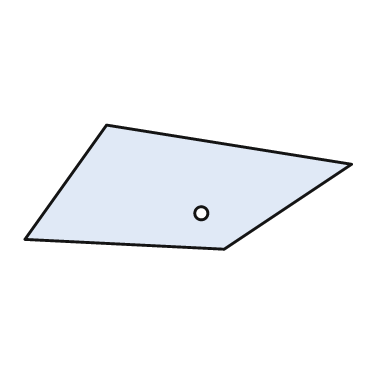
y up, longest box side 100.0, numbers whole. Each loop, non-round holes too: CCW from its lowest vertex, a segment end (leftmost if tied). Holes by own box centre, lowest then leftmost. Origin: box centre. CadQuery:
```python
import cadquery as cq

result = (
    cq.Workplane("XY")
    .moveTo(11.0, -19.0)
    .lineTo(50.0, 7.0)
    .lineTo(-25.0, 19.0)
    .lineTo(-50.0, -16.0)
    .close()
    .moveTo(4.0, -8.0)
    .circle(2.0)
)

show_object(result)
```